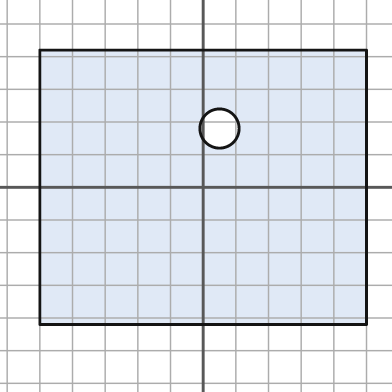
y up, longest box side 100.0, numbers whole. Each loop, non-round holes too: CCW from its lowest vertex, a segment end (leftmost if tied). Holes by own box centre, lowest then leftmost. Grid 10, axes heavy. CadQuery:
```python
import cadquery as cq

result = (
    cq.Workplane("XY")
    .moveTo(-50.0, -42.0)
    .lineTo(50.0, -42.0)
    .lineTo(50.0, 42.0)
    .lineTo(-50.0, 42.0)
    .close()
    .moveTo(5.0, 18.0)
    .circle(6.0)
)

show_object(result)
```